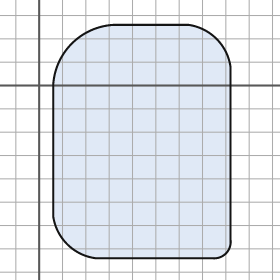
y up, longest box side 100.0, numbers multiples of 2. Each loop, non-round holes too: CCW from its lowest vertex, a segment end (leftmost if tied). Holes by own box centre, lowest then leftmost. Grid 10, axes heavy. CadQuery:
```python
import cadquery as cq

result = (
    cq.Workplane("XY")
    .moveTo(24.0, -74.0)
    .lineTo(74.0, -74.0)
    .threePointArc((80.0, -72.0), (82.0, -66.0))
    .lineTo(82.0, 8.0)
    .threePointArc((76.0, 20.0), (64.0, 26.0))
    .lineTo(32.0, 26.0)
    .threePointArc((14.0, 18.0), (6.0, 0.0))
    .lineTo(6.0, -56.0)
    .threePointArc((12.0, -68.0), (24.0, -74.0))
    .close()
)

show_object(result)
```